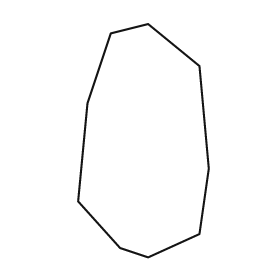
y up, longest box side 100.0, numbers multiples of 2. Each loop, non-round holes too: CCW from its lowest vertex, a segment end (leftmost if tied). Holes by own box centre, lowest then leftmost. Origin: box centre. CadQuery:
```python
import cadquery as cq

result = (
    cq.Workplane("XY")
    .moveTo(2.0, -50.0)
    .lineTo(24.0, -40.0)
    .lineTo(28.0, -12.0)
    .lineTo(24.0, 32.0)
    .lineTo(2.0, 50.0)
    .lineTo(-14.0, 46.0)
    .lineTo(-24.0, 16.0)
    .lineTo(-28.0, -26.0)
    .lineTo(-10.0, -46.0)
    .close()
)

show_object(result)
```